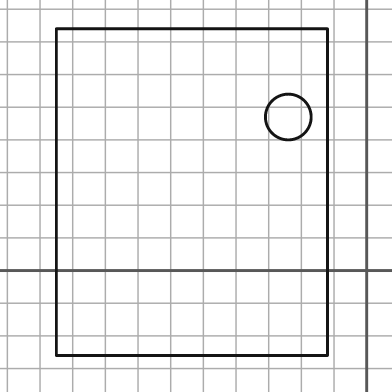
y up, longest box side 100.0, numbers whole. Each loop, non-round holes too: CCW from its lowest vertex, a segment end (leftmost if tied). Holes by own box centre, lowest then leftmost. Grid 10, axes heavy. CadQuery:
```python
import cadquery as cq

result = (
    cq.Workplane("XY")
    .moveTo(-95.0, -26.0)
    .lineTo(-12.0, -26.0)
    .lineTo(-12.0, 74.0)
    .lineTo(-95.0, 74.0)
    .close()
    .moveTo(-24.0, 47.0)
    .circle(7.0)
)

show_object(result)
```